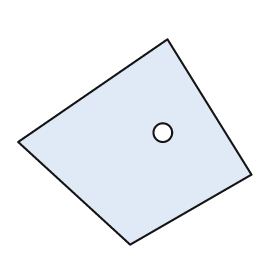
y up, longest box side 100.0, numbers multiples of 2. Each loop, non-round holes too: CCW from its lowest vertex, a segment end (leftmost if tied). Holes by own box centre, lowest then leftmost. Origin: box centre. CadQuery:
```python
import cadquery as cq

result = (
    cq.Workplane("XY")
    .moveTo(-2.0, -44.0)
    .lineTo(50.0, -14.0)
    .lineTo(14.0, 44.0)
    .lineTo(-50.0, 0.0)
    .close()
    .moveTo(12.0, 4.0)
    .circle(4.0)
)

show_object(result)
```